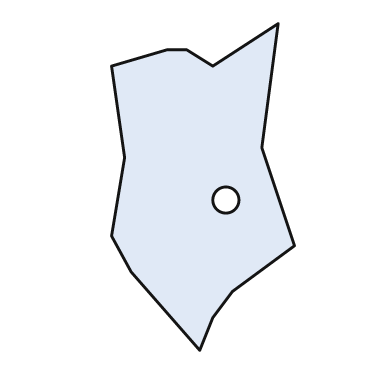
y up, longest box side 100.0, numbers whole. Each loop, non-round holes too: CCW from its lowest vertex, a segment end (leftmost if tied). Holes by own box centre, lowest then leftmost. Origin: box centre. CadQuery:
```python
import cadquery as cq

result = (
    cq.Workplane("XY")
    .moveTo(-1.0, -50.0)
    .lineTo(3.0, -40.0)
    .lineTo(9.0, -32.0)
    .lineTo(28.0, -18.0)
    .lineTo(18.0, 12.0)
    .lineTo(23.0, 50.0)
    .lineTo(3.0, 37.0)
    .lineTo(-5.0, 42.0)
    .lineTo(-11.0, 42.0)
    .lineTo(-28.0, 37.0)
    .lineTo(-24.0, 9.0)
    .lineTo(-28.0, -15.0)
    .lineTo(-22.0, -26.0)
    .close()
    .moveTo(7.0, -4.0)
    .circle(4.0)
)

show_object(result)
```